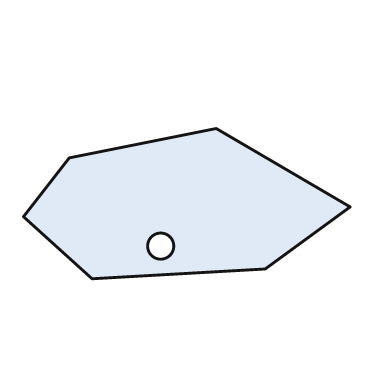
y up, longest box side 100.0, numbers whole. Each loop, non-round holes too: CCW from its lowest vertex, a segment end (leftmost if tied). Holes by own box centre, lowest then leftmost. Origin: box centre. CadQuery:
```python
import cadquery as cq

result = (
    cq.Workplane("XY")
    .moveTo(-29.0, -23.0)
    .lineTo(24.0, -20.0)
    .lineTo(50.0, -1.0)
    .lineTo(9.0, 23.0)
    .lineTo(-36.0, 14.0)
    .lineTo(-50.0, -4.0)
    .close()
    .moveTo(-8.0, -13.0)
    .circle(4.0)
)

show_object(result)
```